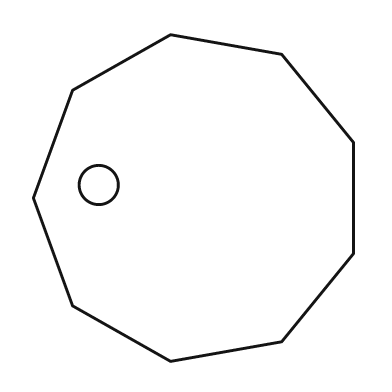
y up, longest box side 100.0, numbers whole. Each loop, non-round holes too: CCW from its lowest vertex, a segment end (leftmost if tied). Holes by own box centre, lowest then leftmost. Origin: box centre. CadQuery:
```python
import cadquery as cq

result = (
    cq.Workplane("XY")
    .moveTo(-7.0, -50.0)
    .lineTo(27.0, -44.0)
    .lineTo(49.0, -17.0)
    .lineTo(49.0, 17.0)
    .lineTo(27.0, 44.0)
    .lineTo(-7.0, 50.0)
    .lineTo(-37.0, 33.0)
    .lineTo(-49.0, 0.0)
    .lineTo(-37.0, -33.0)
    .close()
    .moveTo(-29.0, 4.0)
    .circle(6.0)
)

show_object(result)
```